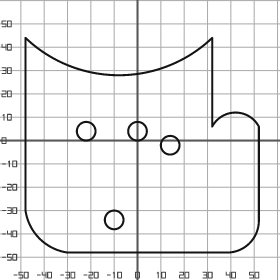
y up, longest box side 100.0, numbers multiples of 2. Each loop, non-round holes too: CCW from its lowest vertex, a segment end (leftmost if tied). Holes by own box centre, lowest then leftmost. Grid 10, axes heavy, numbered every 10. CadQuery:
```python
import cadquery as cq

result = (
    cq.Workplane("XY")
    .moveTo(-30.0, -48.0)
    .lineTo(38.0, -48.0)
    .threePointArc((48.0, -44.0), (52.0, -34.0))
    .lineTo(52.0, 6.0)
    .threePointArc((42.0, 12.0), (32.0, 6.0))
    .lineTo(32.0, 44.0)
    .threePointArc((-8.0, 28.0), (-48.0, 44.0))
    .lineTo(-48.0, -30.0)
    .threePointArc((-42.0, -42.0), (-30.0, -48.0))
    .close()
    .moveTo(-10.0, -34.0)
    .circle(4.0)
    .moveTo(14.0, -2.0)
    .circle(4.0)
    .moveTo(-22.0, 4.0)
    .circle(4.0)
    .moveTo(0.0, 4.0)
    .circle(4.0)
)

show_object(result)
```